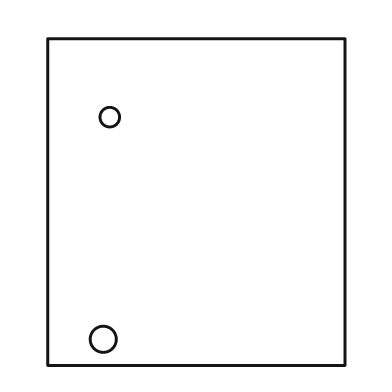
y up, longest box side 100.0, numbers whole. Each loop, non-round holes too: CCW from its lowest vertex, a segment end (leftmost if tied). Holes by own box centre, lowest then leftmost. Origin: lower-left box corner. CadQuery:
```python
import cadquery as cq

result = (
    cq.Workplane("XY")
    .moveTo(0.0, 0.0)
    .lineTo(91.0, 0.0)
    .lineTo(91.0, 100.0)
    .lineTo(0.0, 100.0)
    .close()
    .moveTo(17.0, 8.0)
    .circle(4.0)
    .moveTo(19.0, 76.0)
    .circle(3.0)
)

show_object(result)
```